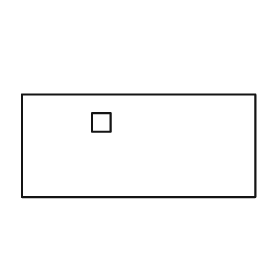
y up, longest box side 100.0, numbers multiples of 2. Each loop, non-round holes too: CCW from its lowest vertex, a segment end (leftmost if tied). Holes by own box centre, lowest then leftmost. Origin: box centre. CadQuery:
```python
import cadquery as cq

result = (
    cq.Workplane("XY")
    .moveTo(-50.0, -22.0)
    .lineTo(50.0, -22.0)
    .lineTo(50.0, 22.0)
    .lineTo(-50.0, 22.0)
    .close()
    .moveTo(-20.0, 6.0)
    .lineTo(-12.0, 6.0)
    .lineTo(-12.0, 14.0)
    .lineTo(-20.0, 14.0)
    .close()
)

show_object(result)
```